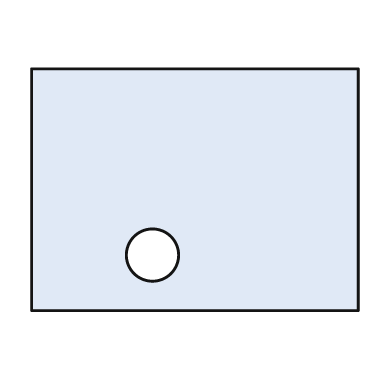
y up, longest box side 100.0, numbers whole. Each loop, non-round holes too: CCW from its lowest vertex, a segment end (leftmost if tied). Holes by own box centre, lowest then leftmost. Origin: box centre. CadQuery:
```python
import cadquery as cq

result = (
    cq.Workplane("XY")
    .moveTo(-50.0, -37.0)
    .lineTo(50.0, -37.0)
    .lineTo(50.0, 37.0)
    .lineTo(-50.0, 37.0)
    .close()
    .moveTo(-13.0, -20.0)
    .circle(8.0)
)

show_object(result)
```